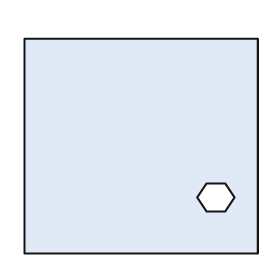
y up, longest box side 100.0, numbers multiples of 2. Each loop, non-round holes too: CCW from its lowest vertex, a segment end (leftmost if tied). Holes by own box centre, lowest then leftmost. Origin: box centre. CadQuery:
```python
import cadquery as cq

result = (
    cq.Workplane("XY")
    .moveTo(-50.0, -46.0)
    .lineTo(50.0, -46.0)
    .lineTo(50.0, 46.0)
    .lineTo(-50.0, 46.0)
    .close()
    .moveTo(28.0, -28.0)
    .lineTo(36.0, -28.0)
    .lineTo(40.0, -22.0)
    .lineTo(36.0, -16.0)
    .lineTo(28.0, -16.0)
    .lineTo(24.0, -22.0)
    .close()
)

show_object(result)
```